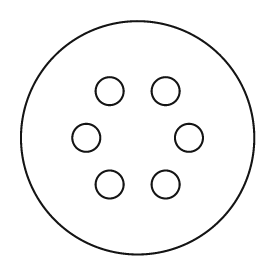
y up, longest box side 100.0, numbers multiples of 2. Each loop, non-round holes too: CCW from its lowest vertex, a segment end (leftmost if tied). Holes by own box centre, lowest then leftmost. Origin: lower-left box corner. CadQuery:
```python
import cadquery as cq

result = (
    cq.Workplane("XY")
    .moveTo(50.0, 50.0)
    .circle(50.0)
    .moveTo(38.0, 30.0)
    .circle(6.0)
    .moveTo(62.0, 30.0)
    .circle(6.0)
    .moveTo(28.0, 50.0)
    .circle(6.0)
    .moveTo(72.0, 50.0)
    .circle(6.0)
    .moveTo(38.0, 70.0)
    .circle(6.0)
    .moveTo(62.0, 70.0)
    .circle(6.0)
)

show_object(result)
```